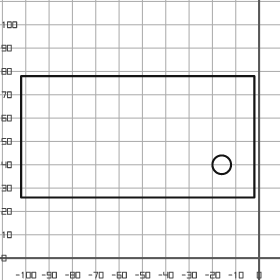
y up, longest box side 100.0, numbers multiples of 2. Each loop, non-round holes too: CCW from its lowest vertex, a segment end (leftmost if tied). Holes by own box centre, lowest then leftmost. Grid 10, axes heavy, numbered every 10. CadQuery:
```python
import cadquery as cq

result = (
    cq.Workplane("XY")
    .moveTo(-102.0, 26.0)
    .lineTo(-2.0, 26.0)
    .lineTo(-2.0, 78.0)
    .lineTo(-102.0, 78.0)
    .close()
    .moveTo(-16.0, 40.0)
    .circle(4.0)
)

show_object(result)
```